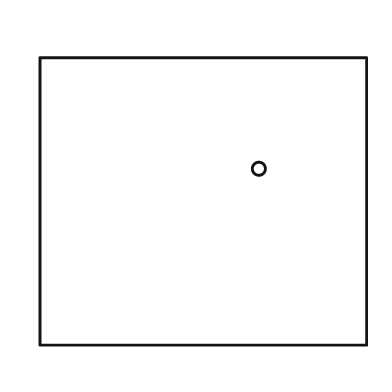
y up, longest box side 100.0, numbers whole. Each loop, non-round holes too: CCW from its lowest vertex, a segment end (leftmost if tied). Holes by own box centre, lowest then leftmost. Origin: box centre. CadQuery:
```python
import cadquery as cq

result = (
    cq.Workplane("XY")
    .moveTo(-50.0, -44.0)
    .lineTo(50.0, -44.0)
    .lineTo(50.0, 44.0)
    .lineTo(-50.0, 44.0)
    .close()
    .moveTo(17.0, 10.0)
    .circle(2.0)
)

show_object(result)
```